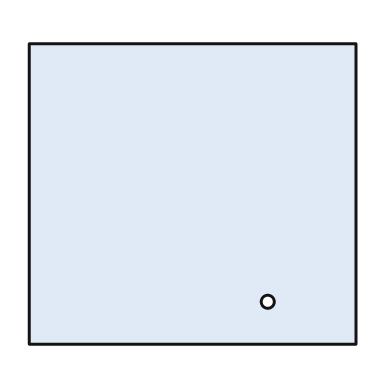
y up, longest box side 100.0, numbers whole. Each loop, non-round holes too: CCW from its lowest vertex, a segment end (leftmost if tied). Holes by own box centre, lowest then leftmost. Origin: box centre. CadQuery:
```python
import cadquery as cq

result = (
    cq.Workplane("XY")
    .moveTo(-50.0, -46.0)
    .lineTo(50.0, -46.0)
    .lineTo(50.0, 46.0)
    .lineTo(-50.0, 46.0)
    .close()
    .moveTo(23.0, -33.0)
    .circle(2.0)
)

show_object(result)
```